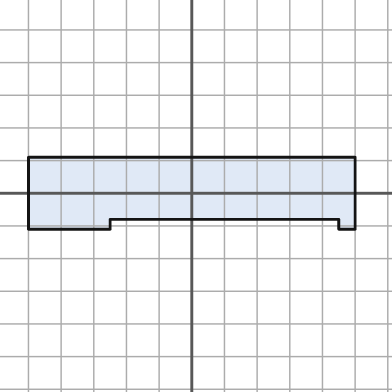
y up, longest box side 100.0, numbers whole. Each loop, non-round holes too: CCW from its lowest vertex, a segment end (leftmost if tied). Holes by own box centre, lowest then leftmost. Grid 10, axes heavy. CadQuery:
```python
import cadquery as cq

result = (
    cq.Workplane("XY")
    .moveTo(-50.0, -11.0)
    .lineTo(-25.0, -11.0)
    .lineTo(-25.0, -8.0)
    .lineTo(45.0, -8.0)
    .lineTo(45.0, -11.0)
    .lineTo(50.0, -11.0)
    .lineTo(50.0, 11.0)
    .lineTo(-50.0, 11.0)
    .close()
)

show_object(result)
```